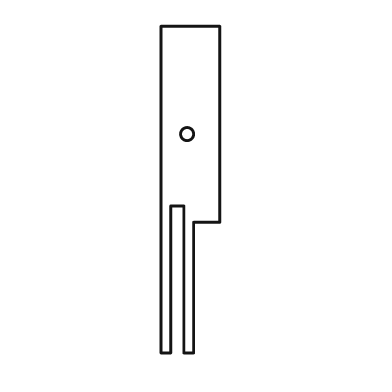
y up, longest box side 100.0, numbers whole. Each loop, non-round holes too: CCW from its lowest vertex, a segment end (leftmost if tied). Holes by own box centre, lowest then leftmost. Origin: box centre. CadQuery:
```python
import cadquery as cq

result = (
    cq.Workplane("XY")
    .moveTo(-9.0, -50.0)
    .lineTo(-6.0, -50.0)
    .lineTo(-6.0, -5.0)
    .lineTo(-2.0, -5.0)
    .lineTo(-2.0, -50.0)
    .lineTo(1.0, -50.0)
    .lineTo(1.0, -10.0)
    .lineTo(9.0, -10.0)
    .lineTo(9.0, 50.0)
    .lineTo(-9.0, 50.0)
    .close()
    .moveTo(-1.0, 17.0)
    .circle(2.0)
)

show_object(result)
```